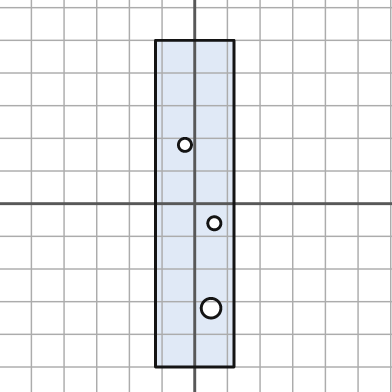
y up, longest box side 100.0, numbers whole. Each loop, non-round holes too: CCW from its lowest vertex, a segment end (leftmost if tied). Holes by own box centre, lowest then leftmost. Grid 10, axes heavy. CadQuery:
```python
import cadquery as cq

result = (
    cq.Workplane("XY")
    .moveTo(-12.0, -50.0)
    .lineTo(12.0, -50.0)
    .lineTo(12.0, 50.0)
    .lineTo(-12.0, 50.0)
    .close()
    .moveTo(5.0, -32.0)
    .circle(3.0)
    .moveTo(6.0, -6.0)
    .circle(2.0)
    .moveTo(-3.0, 18.0)
    .circle(2.0)
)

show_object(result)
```